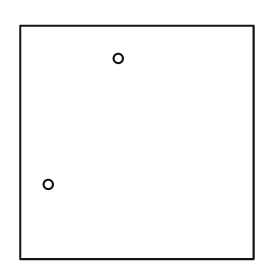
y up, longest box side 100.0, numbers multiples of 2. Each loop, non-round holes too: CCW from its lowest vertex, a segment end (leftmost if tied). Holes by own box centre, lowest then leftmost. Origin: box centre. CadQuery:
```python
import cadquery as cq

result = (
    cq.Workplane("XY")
    .moveTo(-50.0, -50.0)
    .lineTo(50.0, -50.0)
    .lineTo(50.0, 50.0)
    .lineTo(-50.0, 50.0)
    .close()
    .moveTo(-38.0, -18.0)
    .circle(2.0)
    .moveTo(-8.0, 36.0)
    .circle(2.0)
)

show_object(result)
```